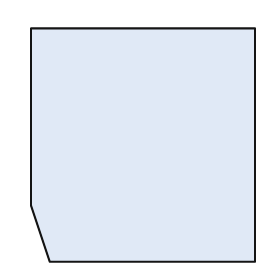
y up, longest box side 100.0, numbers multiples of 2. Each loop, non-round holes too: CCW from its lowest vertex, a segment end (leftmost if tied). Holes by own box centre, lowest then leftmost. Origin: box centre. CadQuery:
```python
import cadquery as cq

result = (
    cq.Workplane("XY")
    .moveTo(-40.0, -50.0)
    .lineTo(48.0, -50.0)
    .lineTo(48.0, 50.0)
    .lineTo(-48.0, 50.0)
    .lineTo(-48.0, -26.0)
    .close()
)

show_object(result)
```